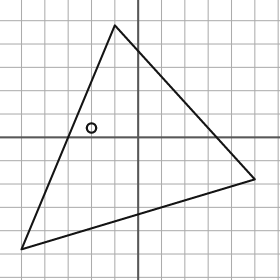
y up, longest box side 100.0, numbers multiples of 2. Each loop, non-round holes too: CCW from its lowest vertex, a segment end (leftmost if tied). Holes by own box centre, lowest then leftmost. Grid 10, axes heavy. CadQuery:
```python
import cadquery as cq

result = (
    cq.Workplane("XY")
    .moveTo(-50.0, -48.0)
    .lineTo(50.0, -18.0)
    .lineTo(-10.0, 48.0)
    .close()
    .moveTo(-20.0, 4.0)
    .circle(2.0)
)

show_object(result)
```